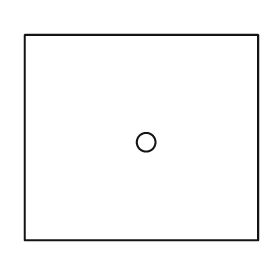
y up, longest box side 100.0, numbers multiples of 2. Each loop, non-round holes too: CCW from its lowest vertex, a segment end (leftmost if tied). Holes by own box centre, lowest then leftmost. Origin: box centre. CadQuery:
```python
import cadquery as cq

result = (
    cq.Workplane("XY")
    .moveTo(-50.0, -44.0)
    .lineTo(50.0, -44.0)
    .lineTo(50.0, 44.0)
    .lineTo(-50.0, 44.0)
    .close()
    .moveTo(2.0, -2.0)
    .circle(4.0)
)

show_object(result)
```